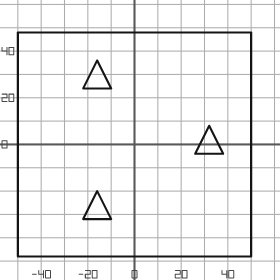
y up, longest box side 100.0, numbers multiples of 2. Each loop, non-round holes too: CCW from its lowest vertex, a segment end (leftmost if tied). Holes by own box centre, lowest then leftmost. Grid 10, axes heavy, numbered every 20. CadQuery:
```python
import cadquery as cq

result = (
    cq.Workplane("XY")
    .moveTo(-50.0, -48.0)
    .lineTo(50.0, -48.0)
    .lineTo(50.0, 48.0)
    .lineTo(-50.0, 48.0)
    .close()
    .moveTo(-22.0, -32.0)
    .lineTo(-10.0, -32.0)
    .lineTo(-16.0, -20.0)
    .close()
    .moveTo(26.0, -4.0)
    .lineTo(38.0, -4.0)
    .lineTo(32.0, 8.0)
    .close()
    .moveTo(-22.0, 24.0)
    .lineTo(-10.0, 24.0)
    .lineTo(-16.0, 36.0)
    .close()
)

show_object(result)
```